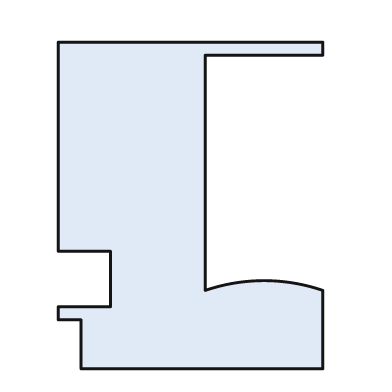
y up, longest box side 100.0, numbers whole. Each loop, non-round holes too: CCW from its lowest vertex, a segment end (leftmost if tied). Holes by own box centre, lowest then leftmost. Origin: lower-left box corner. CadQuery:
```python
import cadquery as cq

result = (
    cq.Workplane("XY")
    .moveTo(7.0, 0.0)
    .lineTo(81.0, 0.0)
    .lineTo(81.0, 24.0)
    .threePointArc((63.0, 27.0), (45.0, 24.0))
    .lineTo(45.0, 96.0)
    .lineTo(81.0, 96.0)
    .lineTo(81.0, 100.0)
    .lineTo(0.0, 100.0)
    .lineTo(0.0, 36.0)
    .lineTo(16.0, 36.0)
    .lineTo(16.0, 19.0)
    .lineTo(0.0, 19.0)
    .lineTo(0.0, 15.0)
    .lineTo(7.0, 15.0)
    .close()
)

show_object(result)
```